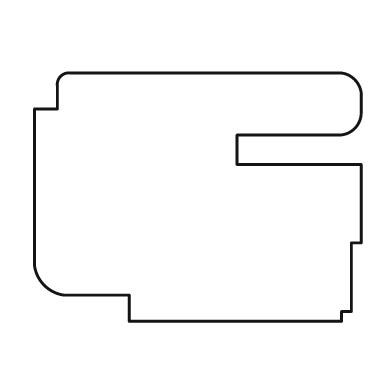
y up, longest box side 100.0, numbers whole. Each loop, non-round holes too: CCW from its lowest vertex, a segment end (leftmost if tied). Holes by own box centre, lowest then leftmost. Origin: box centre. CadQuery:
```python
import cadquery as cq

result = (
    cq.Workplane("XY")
    .moveTo(-21.0, -38.0)
    .lineTo(44.0, -38.0)
    .lineTo(44.0, -35.0)
    .lineTo(47.0, -35.0)
    .lineTo(47.0, -14.0)
    .lineTo(50.0, -14.0)
    .lineTo(50.0, 10.0)
    .lineTo(12.0, 10.0)
    .lineTo(12.0, 19.0)
    .lineTo(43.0, 19.0)
    .threePointArc((48.0, 21.0), (50.0, 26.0))
    .lineTo(50.0, 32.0)
    .threePointArc((48.0, 36.0), (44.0, 38.0))
    .lineTo(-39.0, 38.0)
    .threePointArc((-42.0, 37.0), (-43.0, 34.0))
    .lineTo(-43.0, 27.0)
    .lineTo(-50.0, 27.0)
    .lineTo(-50.0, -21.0)
    .threePointArc((-47.0, -27.0), (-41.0, -30.0))
    .lineTo(-21.0, -30.0)
    .close()
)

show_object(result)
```